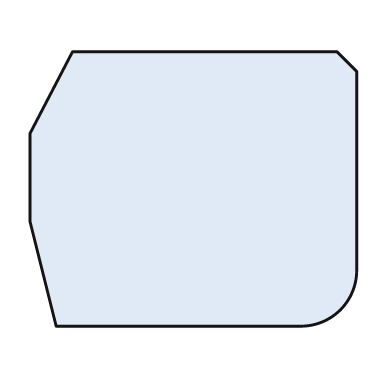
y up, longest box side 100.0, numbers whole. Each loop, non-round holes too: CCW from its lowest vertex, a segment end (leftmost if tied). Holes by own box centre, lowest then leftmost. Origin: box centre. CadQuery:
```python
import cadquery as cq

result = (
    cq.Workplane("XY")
    .moveTo(-42.0, -42.0)
    .lineTo(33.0, -42.0)
    .threePointArc((45.0, -37.0), (50.0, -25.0))
    .lineTo(50.0, 36.0)
    .lineTo(44.0, 42.0)
    .lineTo(-37.0, 42.0)
    .lineTo(-50.0, 17.0)
    .lineTo(-50.0, -10.0)
    .close()
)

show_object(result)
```